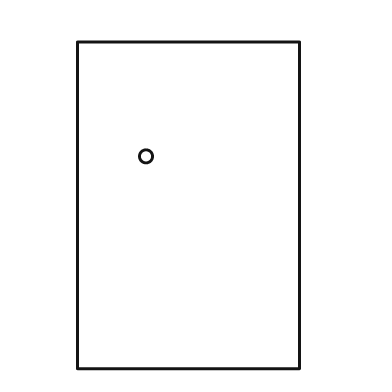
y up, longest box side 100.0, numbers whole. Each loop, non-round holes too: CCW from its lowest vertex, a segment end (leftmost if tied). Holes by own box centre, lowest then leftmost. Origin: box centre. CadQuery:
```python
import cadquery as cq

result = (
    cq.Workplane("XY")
    .moveTo(-34.0, -50.0)
    .lineTo(34.0, -50.0)
    .lineTo(34.0, 50.0)
    .lineTo(-34.0, 50.0)
    .close()
    .moveTo(-13.0, 15.0)
    .circle(2.0)
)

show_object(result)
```